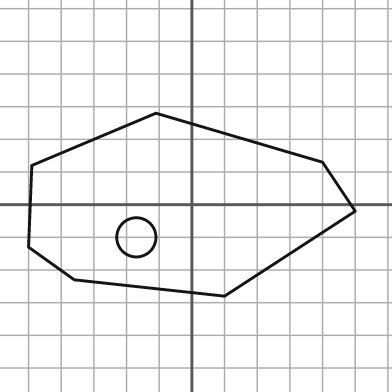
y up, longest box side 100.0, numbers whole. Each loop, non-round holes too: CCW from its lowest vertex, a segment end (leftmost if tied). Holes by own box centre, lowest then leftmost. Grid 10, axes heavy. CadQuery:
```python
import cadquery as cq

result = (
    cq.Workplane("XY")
    .moveTo(10.0, -28.0)
    .lineTo(50.0, -2.0)
    .lineTo(40.0, 13.0)
    .lineTo(-11.0, 28.0)
    .lineTo(-49.0, 12.0)
    .lineTo(-50.0, -13.0)
    .lineTo(-36.0, -23.0)
    .close()
    .moveTo(-17.0, -10.0)
    .circle(6.0)
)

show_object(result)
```